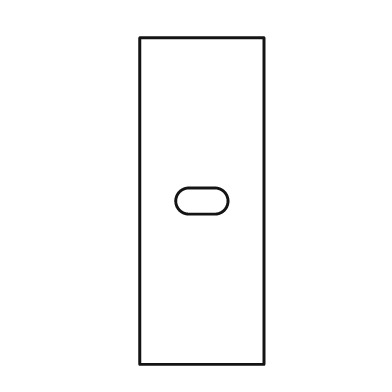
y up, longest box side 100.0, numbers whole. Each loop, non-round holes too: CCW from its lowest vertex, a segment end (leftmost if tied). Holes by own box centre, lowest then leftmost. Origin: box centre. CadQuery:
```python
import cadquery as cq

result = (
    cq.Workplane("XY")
    .moveTo(-19.0, -50.0)
    .lineTo(19.0, -50.0)
    .lineTo(19.0, 50.0)
    .lineTo(-19.0, 50.0)
    .close()
    .moveTo(-4.0, -4.0)
    .lineTo(4.0, -4.0)
    .threePointArc((8.0, 0.0), (4.0, 4.0))
    .lineTo(-4.0, 4.0)
    .threePointArc((-8.0, 0.0), (-4.0, -4.0))
    .close()
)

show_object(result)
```